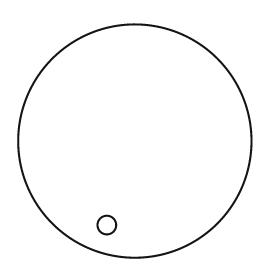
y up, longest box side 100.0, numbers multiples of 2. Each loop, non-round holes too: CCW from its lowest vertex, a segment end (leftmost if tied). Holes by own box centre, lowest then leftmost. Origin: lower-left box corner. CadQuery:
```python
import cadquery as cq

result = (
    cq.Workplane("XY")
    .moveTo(50.0, 50.0)
    .circle(50.0)
    .moveTo(38.0, 14.0)
    .circle(4.0)
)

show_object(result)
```